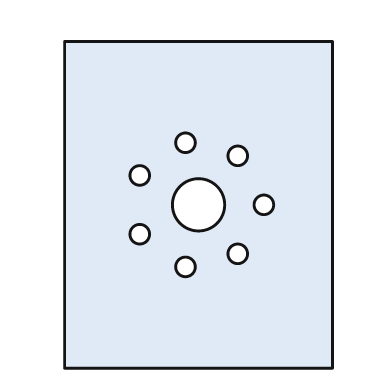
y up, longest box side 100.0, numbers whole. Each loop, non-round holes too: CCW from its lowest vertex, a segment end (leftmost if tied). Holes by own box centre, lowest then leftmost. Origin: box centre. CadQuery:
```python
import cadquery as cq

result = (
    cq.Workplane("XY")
    .moveTo(-41.0, -50.0)
    .lineTo(41.0, -50.0)
    .lineTo(41.0, 50.0)
    .lineTo(-41.0, 50.0)
    .close()
    .moveTo(-4.0, -19.0)
    .circle(3.0)
    .moveTo(12.0, -15.0)
    .circle(3.0)
    .moveTo(-18.0, -9.0)
    .circle(3.0)
    .moveTo(0.0, 0.0)
    .circle(8.0)
    .moveTo(20.0, 0.0)
    .circle(3.0)
    .moveTo(-18.0, 9.0)
    .circle(3.0)
    .moveTo(12.0, 15.0)
    .circle(3.0)
    .moveTo(-4.0, 19.0)
    .circle(3.0)
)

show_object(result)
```